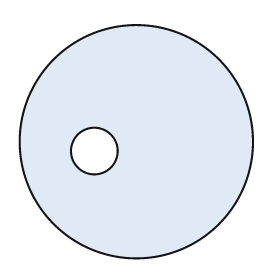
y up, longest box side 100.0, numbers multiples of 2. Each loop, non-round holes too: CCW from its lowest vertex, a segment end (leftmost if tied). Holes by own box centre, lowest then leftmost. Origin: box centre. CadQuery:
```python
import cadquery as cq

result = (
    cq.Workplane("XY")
    .moveTo(0.0, 0.0)
    .circle(50.0)
    .moveTo(-18.0, -4.0)
    .circle(10.0)
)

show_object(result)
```